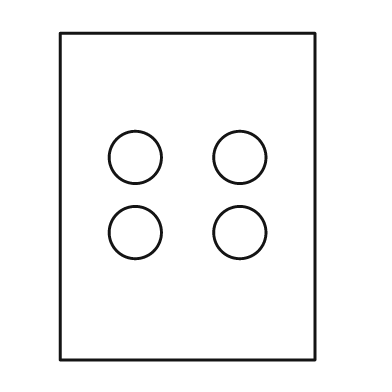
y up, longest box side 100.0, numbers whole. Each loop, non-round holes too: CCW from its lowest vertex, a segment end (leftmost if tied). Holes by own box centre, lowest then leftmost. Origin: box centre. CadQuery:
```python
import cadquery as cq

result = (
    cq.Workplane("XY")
    .moveTo(-39.0, -50.0)
    .lineTo(39.0, -50.0)
    .lineTo(39.0, 50.0)
    .lineTo(-39.0, 50.0)
    .close()
    .moveTo(-16.0, -11.0)
    .circle(8.0)
    .moveTo(16.0, -11.0)
    .circle(8.0)
    .moveTo(-16.0, 12.0)
    .circle(8.0)
    .moveTo(16.0, 12.0)
    .circle(8.0)
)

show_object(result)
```